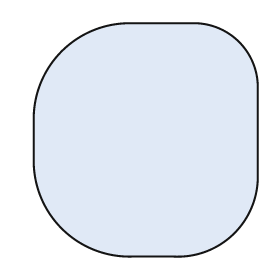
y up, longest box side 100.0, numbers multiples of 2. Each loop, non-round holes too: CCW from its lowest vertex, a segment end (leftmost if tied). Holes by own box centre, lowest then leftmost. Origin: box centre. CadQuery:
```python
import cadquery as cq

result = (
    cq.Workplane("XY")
    .moveTo(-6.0, -50.0)
    .lineTo(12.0, -50.0)
    .threePointArc((38.0, -40.0), (48.0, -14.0))
    .lineTo(48.0, 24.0)
    .threePointArc((40.0, 42.0), (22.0, 50.0))
    .lineTo(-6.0, 50.0)
    .threePointArc((-36.0, 38.0), (-48.0, 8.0))
    .lineTo(-48.0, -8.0)
    .threePointArc((-36.0, -38.0), (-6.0, -50.0))
    .close()
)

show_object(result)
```